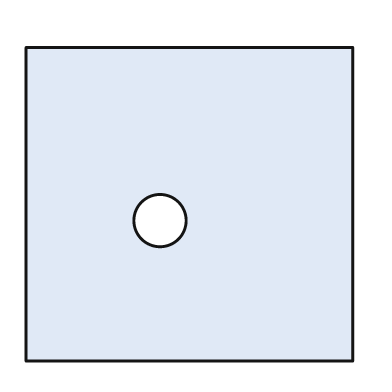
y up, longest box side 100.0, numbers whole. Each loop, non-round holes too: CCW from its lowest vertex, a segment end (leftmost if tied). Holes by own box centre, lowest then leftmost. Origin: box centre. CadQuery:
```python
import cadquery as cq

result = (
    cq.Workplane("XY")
    .moveTo(-50.0, -48.0)
    .lineTo(50.0, -48.0)
    .lineTo(50.0, 48.0)
    .lineTo(-50.0, 48.0)
    .close()
    .moveTo(-9.0, -5.0)
    .circle(8.0)
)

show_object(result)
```